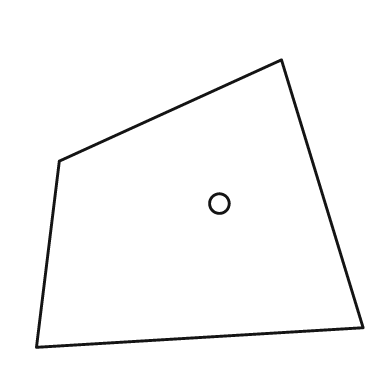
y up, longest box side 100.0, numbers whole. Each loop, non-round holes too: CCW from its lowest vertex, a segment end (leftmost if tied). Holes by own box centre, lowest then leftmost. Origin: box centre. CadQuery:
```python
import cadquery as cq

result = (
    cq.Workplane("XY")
    .moveTo(-50.0, -44.0)
    .lineTo(50.0, -38.0)
    .lineTo(25.0, 44.0)
    .lineTo(-43.0, 13.0)
    .close()
    .moveTo(6.0, 0.0)
    .circle(3.0)
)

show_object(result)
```